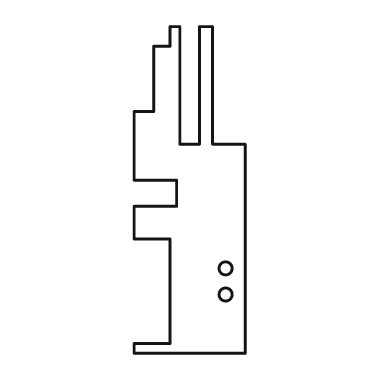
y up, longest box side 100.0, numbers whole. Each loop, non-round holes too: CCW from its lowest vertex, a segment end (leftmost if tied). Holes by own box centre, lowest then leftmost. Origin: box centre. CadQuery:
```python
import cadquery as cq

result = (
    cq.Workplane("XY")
    .moveTo(-17.0, -50.0)
    .lineTo(17.0, -50.0)
    .lineTo(17.0, 14.0)
    .lineTo(7.0, 14.0)
    .lineTo(7.0, 50.0)
    .lineTo(3.0, 50.0)
    .lineTo(3.0, 14.0)
    .lineTo(-3.0, 14.0)
    .lineTo(-3.0, 50.0)
    .lineTo(-6.0, 50.0)
    .lineTo(-6.0, 44.0)
    .lineTo(-11.0, 44.0)
    .lineTo(-11.0, 24.0)
    .lineTo(-17.0, 24.0)
    .lineTo(-17.0, 3.0)
    .lineTo(-4.0, 3.0)
    .lineTo(-4.0, -5.0)
    .lineTo(-17.0, -5.0)
    .lineTo(-17.0, -15.0)
    .lineTo(-6.0, -15.0)
    .lineTo(-6.0, -47.0)
    .lineTo(-17.0, -47.0)
    .close()
    .moveTo(11.0, -32.0)
    .circle(2.0)
    .moveTo(11.0, -24.0)
    .circle(2.0)
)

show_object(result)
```